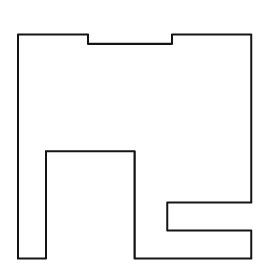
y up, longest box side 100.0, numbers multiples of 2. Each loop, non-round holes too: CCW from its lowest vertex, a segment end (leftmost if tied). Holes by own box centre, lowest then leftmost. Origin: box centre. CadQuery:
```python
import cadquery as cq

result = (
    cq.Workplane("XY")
    .moveTo(-50.0, -48.0)
    .lineTo(-38.0, -48.0)
    .lineTo(-38.0, -2.0)
    .lineTo(0.0, -2.0)
    .lineTo(0.0, -48.0)
    .lineTo(50.0, -48.0)
    .lineTo(50.0, -36.0)
    .lineTo(14.0, -36.0)
    .lineTo(14.0, -24.0)
    .lineTo(50.0, -24.0)
    .lineTo(50.0, 48.0)
    .lineTo(16.0, 48.0)
    .lineTo(16.0, 44.0)
    .lineTo(-20.0, 44.0)
    .lineTo(-20.0, 48.0)
    .lineTo(-50.0, 48.0)
    .close()
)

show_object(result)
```